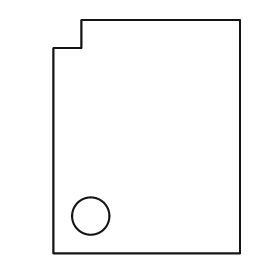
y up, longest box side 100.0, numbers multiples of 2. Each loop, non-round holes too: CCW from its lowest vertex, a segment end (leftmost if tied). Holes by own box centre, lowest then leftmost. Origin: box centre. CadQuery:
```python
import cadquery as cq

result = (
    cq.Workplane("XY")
    .moveTo(-40.0, -50.0)
    .lineTo(40.0, -50.0)
    .lineTo(40.0, 50.0)
    .lineTo(-28.0, 50.0)
    .lineTo(-28.0, 38.0)
    .lineTo(-40.0, 38.0)
    .close()
    .moveTo(-24.0, -34.0)
    .circle(8.0)
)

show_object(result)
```